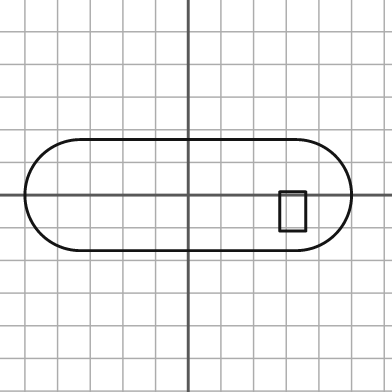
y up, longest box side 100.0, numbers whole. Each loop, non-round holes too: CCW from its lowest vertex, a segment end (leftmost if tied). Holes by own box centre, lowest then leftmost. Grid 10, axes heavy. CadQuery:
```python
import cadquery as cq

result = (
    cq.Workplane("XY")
    .moveTo(-33.0, -17.0)
    .lineTo(33.0, -17.0)
    .threePointArc((50.0, 0.0), (33.0, 17.0))
    .lineTo(-33.0, 17.0)
    .threePointArc((-50.0, 0.0), (-33.0, -17.0))
    .close()
    .moveTo(28.0, -11.0)
    .lineTo(36.0, -11.0)
    .lineTo(36.0, 1.0)
    .lineTo(28.0, 1.0)
    .close()
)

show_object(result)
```